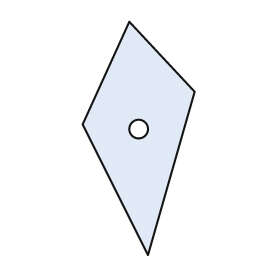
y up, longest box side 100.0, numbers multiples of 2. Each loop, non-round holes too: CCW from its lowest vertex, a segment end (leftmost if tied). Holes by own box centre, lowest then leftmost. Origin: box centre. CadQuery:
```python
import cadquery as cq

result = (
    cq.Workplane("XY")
    .moveTo(4.0, -50.0)
    .lineTo(24.0, 20.0)
    .lineTo(-4.0, 50.0)
    .lineTo(-24.0, 6.0)
    .close()
    .moveTo(0.0, 4.0)
    .circle(4.0)
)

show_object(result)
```